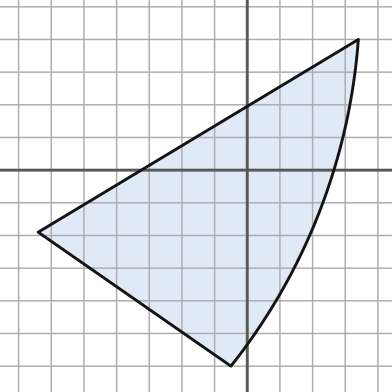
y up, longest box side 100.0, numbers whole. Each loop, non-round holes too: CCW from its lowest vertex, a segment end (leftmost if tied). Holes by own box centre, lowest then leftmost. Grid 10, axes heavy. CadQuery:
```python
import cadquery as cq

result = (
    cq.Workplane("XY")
    .moveTo(-5.0, -60.0)
    .threePointArc((22.0, -13.0), (34.0, 40.0))
    .lineTo(-64.0, -19.0)
    .close()
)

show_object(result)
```